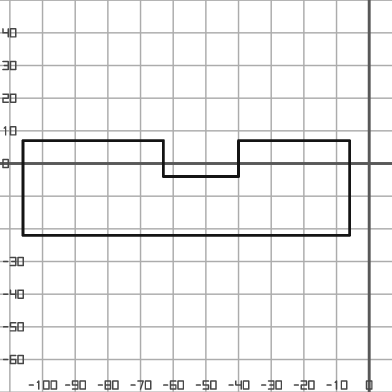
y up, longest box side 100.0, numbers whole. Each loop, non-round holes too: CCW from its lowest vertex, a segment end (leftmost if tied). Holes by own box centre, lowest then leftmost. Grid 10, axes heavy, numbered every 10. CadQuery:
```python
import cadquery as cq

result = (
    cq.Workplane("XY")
    .moveTo(-106.0, -22.0)
    .lineTo(-6.0, -22.0)
    .lineTo(-6.0, 7.0)
    .lineTo(-40.0, 7.0)
    .lineTo(-40.0, -4.0)
    .lineTo(-63.0, -4.0)
    .lineTo(-63.0, 7.0)
    .lineTo(-106.0, 7.0)
    .close()
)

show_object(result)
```